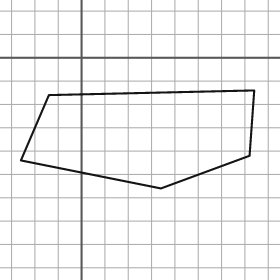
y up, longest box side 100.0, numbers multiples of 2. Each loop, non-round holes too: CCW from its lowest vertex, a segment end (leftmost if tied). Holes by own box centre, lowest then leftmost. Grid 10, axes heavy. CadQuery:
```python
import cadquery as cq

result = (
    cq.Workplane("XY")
    .moveTo(34.0, -56.0)
    .lineTo(72.0, -42.0)
    .lineTo(74.0, -14.0)
    .lineTo(-14.0, -16.0)
    .lineTo(-26.0, -44.0)
    .close()
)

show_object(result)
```